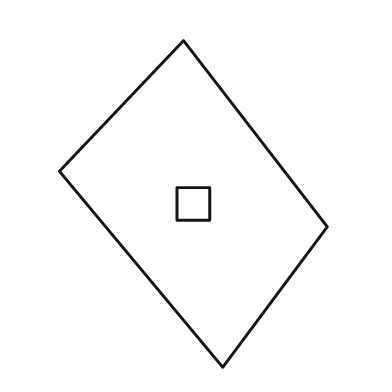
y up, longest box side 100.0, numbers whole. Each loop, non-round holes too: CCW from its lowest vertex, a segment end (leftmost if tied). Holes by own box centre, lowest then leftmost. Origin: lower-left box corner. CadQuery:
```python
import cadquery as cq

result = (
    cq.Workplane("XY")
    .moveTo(50.0, 0.0)
    .lineTo(82.0, 43.0)
    .lineTo(38.0, 100.0)
    .lineTo(0.0, 60.0)
    .close()
    .moveTo(36.0, 45.0)
    .lineTo(46.0, 45.0)
    .lineTo(46.0, 55.0)
    .lineTo(36.0, 55.0)
    .close()
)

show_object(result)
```